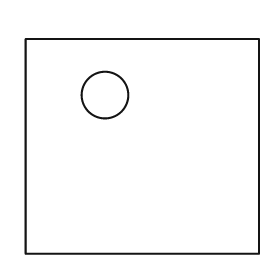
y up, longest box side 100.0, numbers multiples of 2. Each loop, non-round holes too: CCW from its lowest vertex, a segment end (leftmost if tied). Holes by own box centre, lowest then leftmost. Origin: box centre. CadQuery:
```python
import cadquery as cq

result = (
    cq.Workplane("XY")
    .moveTo(-50.0, -46.0)
    .lineTo(50.0, -46.0)
    .lineTo(50.0, 46.0)
    .lineTo(-50.0, 46.0)
    .close()
    .moveTo(-16.0, 22.0)
    .circle(10.0)
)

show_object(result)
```